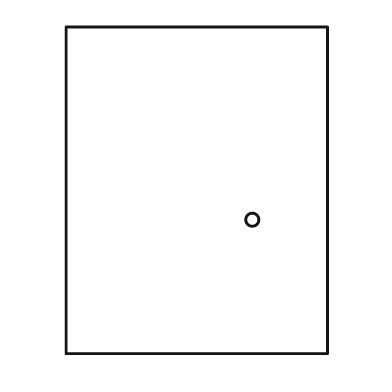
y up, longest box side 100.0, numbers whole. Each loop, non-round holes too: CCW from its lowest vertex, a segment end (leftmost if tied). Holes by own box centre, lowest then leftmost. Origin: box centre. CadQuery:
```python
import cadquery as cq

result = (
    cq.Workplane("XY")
    .moveTo(-40.0, -50.0)
    .lineTo(40.0, -50.0)
    .lineTo(40.0, 50.0)
    .lineTo(-40.0, 50.0)
    .close()
    .moveTo(17.0, -9.0)
    .circle(2.0)
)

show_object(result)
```